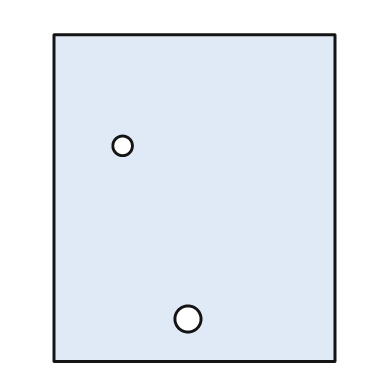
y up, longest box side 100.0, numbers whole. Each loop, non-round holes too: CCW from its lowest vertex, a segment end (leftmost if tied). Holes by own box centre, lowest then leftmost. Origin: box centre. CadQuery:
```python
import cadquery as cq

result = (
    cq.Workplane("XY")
    .moveTo(-43.0, -50.0)
    .lineTo(43.0, -50.0)
    .lineTo(43.0, 50.0)
    .lineTo(-43.0, 50.0)
    .close()
    .moveTo(-2.0, -37.0)
    .circle(4.0)
    .moveTo(-22.0, 16.0)
    .circle(3.0)
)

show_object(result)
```